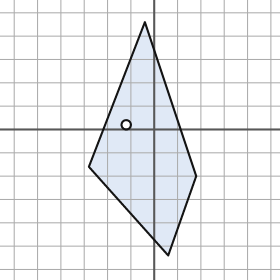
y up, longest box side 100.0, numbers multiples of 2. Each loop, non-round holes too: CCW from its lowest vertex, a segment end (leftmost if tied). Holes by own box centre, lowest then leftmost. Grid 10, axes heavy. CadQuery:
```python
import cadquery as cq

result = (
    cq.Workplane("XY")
    .moveTo(6.0, -54.0)
    .lineTo(18.0, -20.0)
    .lineTo(-4.0, 46.0)
    .lineTo(-28.0, -16.0)
    .close()
    .moveTo(-12.0, 2.0)
    .circle(2.0)
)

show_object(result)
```